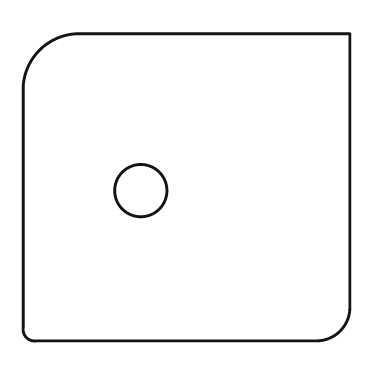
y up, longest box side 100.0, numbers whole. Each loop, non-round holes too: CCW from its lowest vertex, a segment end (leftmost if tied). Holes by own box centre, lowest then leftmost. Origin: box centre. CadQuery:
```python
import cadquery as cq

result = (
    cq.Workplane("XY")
    .moveTo(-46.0, -47.0)
    .lineTo(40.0, -47.0)
    .threePointArc((47.0, -44.0), (50.0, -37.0))
    .lineTo(50.0, 47.0)
    .lineTo(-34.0, 47.0)
    .threePointArc((-45.0, 42.0), (-50.0, 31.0))
    .lineTo(-50.0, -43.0)
    .threePointArc((-49.0, -46.0), (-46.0, -47.0))
    .close()
    .moveTo(-14.0, -1.0)
    .circle(8.0)
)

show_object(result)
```